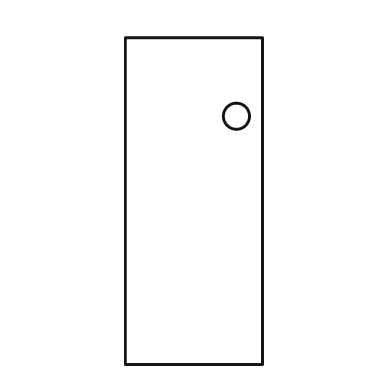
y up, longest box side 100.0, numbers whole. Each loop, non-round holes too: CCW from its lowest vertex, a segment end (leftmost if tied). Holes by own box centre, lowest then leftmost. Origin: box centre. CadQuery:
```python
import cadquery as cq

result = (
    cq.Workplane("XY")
    .moveTo(-21.0, -50.0)
    .lineTo(21.0, -50.0)
    .lineTo(21.0, 50.0)
    .lineTo(-21.0, 50.0)
    .close()
    .moveTo(13.0, 26.0)
    .circle(4.0)
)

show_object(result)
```